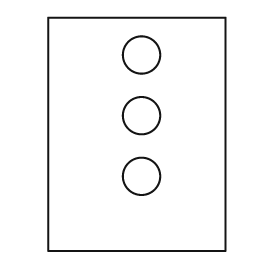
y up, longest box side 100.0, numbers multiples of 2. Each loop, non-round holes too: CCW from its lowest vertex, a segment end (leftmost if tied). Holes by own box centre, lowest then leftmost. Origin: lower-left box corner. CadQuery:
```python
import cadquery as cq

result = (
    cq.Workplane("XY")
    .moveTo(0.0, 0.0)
    .lineTo(76.0, 0.0)
    .lineTo(76.0, 100.0)
    .lineTo(0.0, 100.0)
    .close()
    .moveTo(40.0, 32.0)
    .circle(8.0)
    .moveTo(40.0, 58.0)
    .circle(8.0)
    .moveTo(40.0, 84.0)
    .circle(8.0)
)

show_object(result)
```